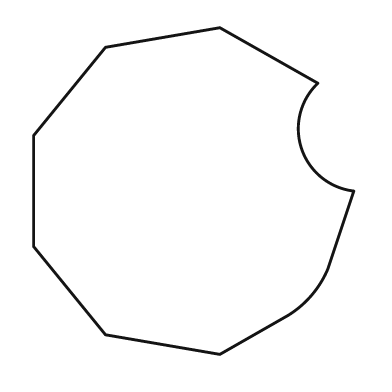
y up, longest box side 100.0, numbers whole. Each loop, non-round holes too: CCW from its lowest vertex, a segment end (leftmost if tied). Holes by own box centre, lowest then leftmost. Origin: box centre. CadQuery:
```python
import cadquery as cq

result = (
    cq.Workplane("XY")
    .moveTo(8.0, -50.0)
    .lineTo(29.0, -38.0)
    .threePointArc((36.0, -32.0), (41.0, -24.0))
    .lineTo(49.0, 0.0)
    .threePointArc((33.0, 13.0), (38.0, 33.0))
    .lineTo(8.0, 50.0)
    .lineTo(-27.0, 44.0)
    .lineTo(-49.0, 17.0)
    .lineTo(-49.0, -17.0)
    .lineTo(-27.0, -44.0)
    .close()
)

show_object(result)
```